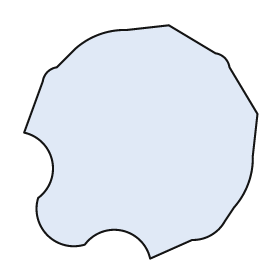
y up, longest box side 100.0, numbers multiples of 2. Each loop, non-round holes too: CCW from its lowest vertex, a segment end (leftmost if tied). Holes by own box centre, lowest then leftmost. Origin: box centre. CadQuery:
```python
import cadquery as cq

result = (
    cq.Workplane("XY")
    .moveTo(4.0, -50.0)
    .lineTo(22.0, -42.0)
    .threePointArc((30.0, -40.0), (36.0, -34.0))
    .lineTo(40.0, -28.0)
    .threePointArc((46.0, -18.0), (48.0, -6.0))
    .lineTo(50.0, 12.0)
    .lineTo(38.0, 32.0)
    .threePointArc((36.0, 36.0), (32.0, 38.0))
    .lineTo(12.0, 50.0)
    .lineTo(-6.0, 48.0)
    .threePointArc((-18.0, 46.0), (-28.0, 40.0))
    .lineTo(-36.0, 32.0)
    .threePointArc((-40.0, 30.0), (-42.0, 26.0))
    .lineTo(-50.0, 4.0)
    .threePointArc((-38.0, -8.0), (-44.0, -24.0))
    .threePointArc((-40.0, -40.0), (-24.0, -44.0))
    .threePointArc((-8.0, -38.0), (4.0, -50.0))
    .close()
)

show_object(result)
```